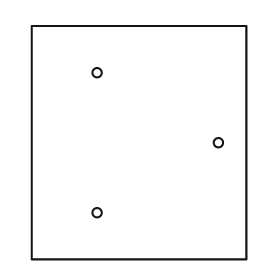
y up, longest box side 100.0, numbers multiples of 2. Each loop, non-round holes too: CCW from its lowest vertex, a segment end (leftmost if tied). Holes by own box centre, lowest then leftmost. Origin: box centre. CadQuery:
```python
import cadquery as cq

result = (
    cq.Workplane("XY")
    .moveTo(-46.0, -50.0)
    .lineTo(46.0, -50.0)
    .lineTo(46.0, 50.0)
    .lineTo(-46.0, 50.0)
    .close()
    .moveTo(-18.0, -30.0)
    .circle(2.0)
    .moveTo(34.0, 0.0)
    .circle(2.0)
    .moveTo(-18.0, 30.0)
    .circle(2.0)
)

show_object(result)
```